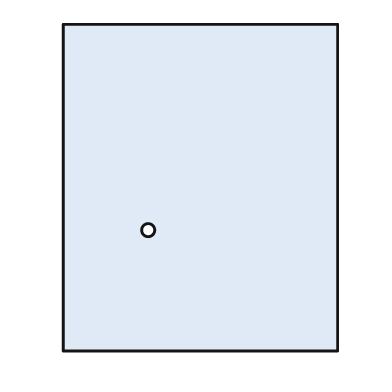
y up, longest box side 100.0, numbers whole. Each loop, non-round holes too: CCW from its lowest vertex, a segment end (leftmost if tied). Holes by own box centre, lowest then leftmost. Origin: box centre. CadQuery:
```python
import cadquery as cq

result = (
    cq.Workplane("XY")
    .moveTo(-42.0, -50.0)
    .lineTo(42.0, -50.0)
    .lineTo(42.0, 50.0)
    .lineTo(-42.0, 50.0)
    .close()
    .moveTo(-16.0, -13.0)
    .circle(2.0)
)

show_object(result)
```